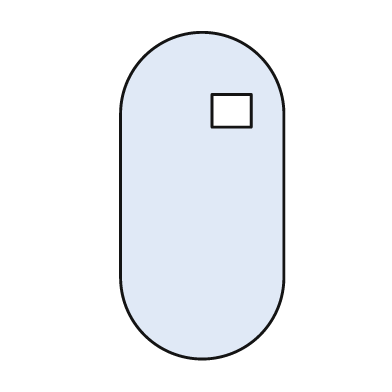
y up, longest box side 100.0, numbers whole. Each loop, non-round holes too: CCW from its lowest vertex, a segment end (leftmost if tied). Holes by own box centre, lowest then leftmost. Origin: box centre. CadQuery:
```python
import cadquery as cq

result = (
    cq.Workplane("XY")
    .moveTo(-25.0, -25.0)
    .threePointArc((0.0, -50.0), (25.0, -25.0))
    .lineTo(25.0, 25.0)
    .threePointArc((0.0, 50.0), (-25.0, 25.0))
    .close()
    .moveTo(3.0, 21.0)
    .lineTo(15.0, 21.0)
    .lineTo(15.0, 31.0)
    .lineTo(3.0, 31.0)
    .close()
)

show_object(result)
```